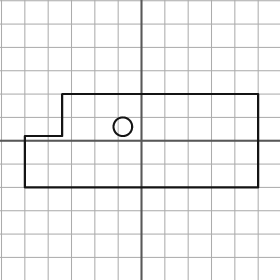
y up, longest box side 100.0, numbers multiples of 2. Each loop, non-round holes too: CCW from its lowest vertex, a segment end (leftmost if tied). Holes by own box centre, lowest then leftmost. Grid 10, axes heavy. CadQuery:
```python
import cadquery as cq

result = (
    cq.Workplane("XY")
    .moveTo(-50.0, -20.0)
    .lineTo(50.0, -20.0)
    .lineTo(50.0, 20.0)
    .lineTo(-34.0, 20.0)
    .lineTo(-34.0, 2.0)
    .lineTo(-50.0, 2.0)
    .close()
    .moveTo(-8.0, 6.0)
    .circle(4.0)
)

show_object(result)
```